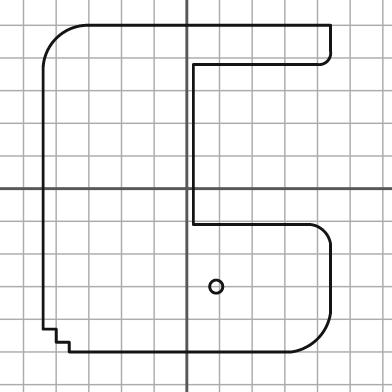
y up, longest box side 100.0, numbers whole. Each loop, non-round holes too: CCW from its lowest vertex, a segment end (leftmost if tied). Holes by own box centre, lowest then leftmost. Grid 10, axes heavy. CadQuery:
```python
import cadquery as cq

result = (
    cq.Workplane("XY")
    .moveTo(-36.0, -50.0)
    .lineTo(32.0, -50.0)
    .threePointArc((40.0, -46.0), (44.0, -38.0))
    .lineTo(44.0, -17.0)
    .threePointArc((42.0, -13.0), (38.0, -11.0))
    .lineTo(2.0, -11.0)
    .lineTo(2.0, 38.0)
    .lineTo(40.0, 38.0)
    .threePointArc((43.0, 39.0), (44.0, 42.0))
    .lineTo(44.0, 50.0)
    .lineTo(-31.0, 50.0)
    .threePointArc((-40.0, 46.0), (-44.0, 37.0))
    .lineTo(-44.0, -43.0)
    .lineTo(-40.0, -43.0)
    .lineTo(-40.0, -47.0)
    .lineTo(-36.0, -47.0)
    .close()
    .moveTo(9.0, -30.0)
    .circle(2.0)
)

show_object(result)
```